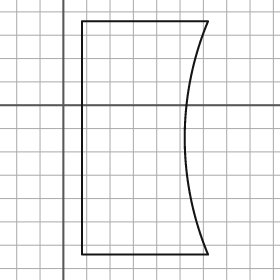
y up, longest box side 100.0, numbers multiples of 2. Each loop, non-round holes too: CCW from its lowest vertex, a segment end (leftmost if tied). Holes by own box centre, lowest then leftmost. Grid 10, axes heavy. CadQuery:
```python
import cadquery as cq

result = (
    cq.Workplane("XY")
    .moveTo(8.0, -64.0)
    .lineTo(62.0, -64.0)
    .threePointArc((52.0, -14.0), (62.0, 36.0))
    .lineTo(8.0, 36.0)
    .close()
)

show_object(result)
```